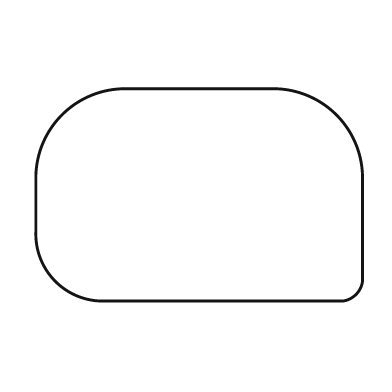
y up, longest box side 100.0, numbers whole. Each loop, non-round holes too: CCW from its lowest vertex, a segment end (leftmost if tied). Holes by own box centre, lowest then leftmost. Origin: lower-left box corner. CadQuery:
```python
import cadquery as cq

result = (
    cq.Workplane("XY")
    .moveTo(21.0, 0.0)
    .lineTo(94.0, 0.0)
    .threePointArc((98.0, 2.0), (100.0, 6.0))
    .lineTo(100.0, 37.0)
    .threePointArc((92.0, 57.0), (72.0, 65.0))
    .lineTo(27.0, 65.0)
    .threePointArc((8.0, 57.0), (0.0, 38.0))
    .lineTo(0.0, 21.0)
    .threePointArc((6.0, 6.0), (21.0, 0.0))
    .close()
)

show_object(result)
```